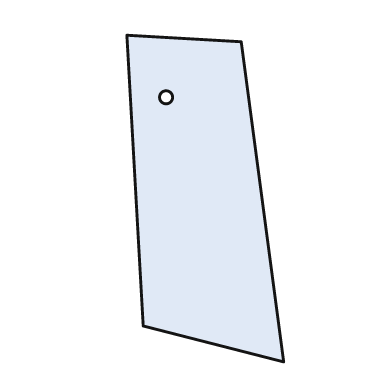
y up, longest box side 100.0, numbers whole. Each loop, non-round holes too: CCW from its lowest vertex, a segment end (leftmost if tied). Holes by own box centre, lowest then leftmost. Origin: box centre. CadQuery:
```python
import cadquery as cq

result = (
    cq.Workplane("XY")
    .moveTo(24.0, -50.0)
    .lineTo(11.0, 48.0)
    .lineTo(-24.0, 50.0)
    .lineTo(-19.0, -39.0)
    .close()
    .moveTo(-12.0, 31.0)
    .circle(2.0)
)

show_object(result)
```